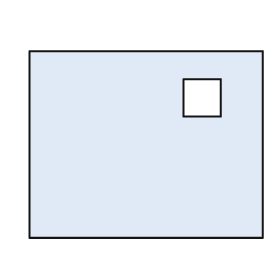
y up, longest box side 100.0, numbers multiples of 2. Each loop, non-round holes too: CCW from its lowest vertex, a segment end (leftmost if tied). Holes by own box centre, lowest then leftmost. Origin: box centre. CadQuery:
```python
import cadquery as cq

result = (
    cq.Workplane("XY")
    .moveTo(-50.0, -40.0)
    .lineTo(50.0, -40.0)
    .lineTo(50.0, 40.0)
    .lineTo(-50.0, 40.0)
    .close()
    .moveTo(16.0, 12.0)
    .lineTo(32.0, 12.0)
    .lineTo(32.0, 28.0)
    .lineTo(16.0, 28.0)
    .close()
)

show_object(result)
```